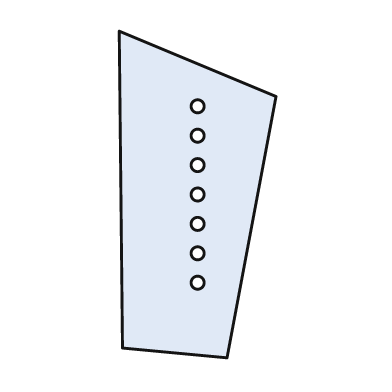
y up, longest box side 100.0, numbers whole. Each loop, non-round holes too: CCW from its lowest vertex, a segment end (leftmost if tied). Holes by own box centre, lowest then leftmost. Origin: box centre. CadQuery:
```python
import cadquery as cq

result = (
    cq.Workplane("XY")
    .moveTo(9.0, -50.0)
    .lineTo(24.0, 30.0)
    .lineTo(-24.0, 50.0)
    .lineTo(-23.0, -47.0)
    .close()
    .moveTo(0.0, -27.0)
    .circle(2.0)
    .moveTo(0.0, -18.0)
    .circle(2.0)
    .moveTo(0.0, -9.0)
    .circle(2.0)
    .moveTo(0.0, 0.0)
    .circle(2.0)
    .moveTo(0.0, 9.0)
    .circle(2.0)
    .moveTo(0.0, 18.0)
    .circle(2.0)
    .moveTo(0.0, 27.0)
    .circle(2.0)
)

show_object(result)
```